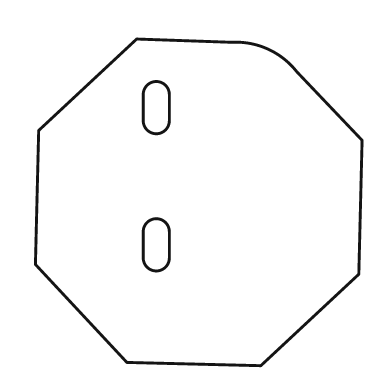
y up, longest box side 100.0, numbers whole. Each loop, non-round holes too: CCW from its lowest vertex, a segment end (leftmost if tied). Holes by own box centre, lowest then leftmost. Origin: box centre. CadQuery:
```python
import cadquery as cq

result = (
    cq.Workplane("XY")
    .moveTo(19.0, -50.0)
    .lineTo(49.0, -22.0)
    .lineTo(50.0, 19.0)
    .lineTo(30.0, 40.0)
    .threePointArc((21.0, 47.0), (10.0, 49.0))
    .lineTo(-19.0, 50.0)
    .lineTo(-49.0, 22.0)
    .lineTo(-50.0, -19.0)
    .lineTo(-22.0, -49.0)
    .close()
    .moveTo(-17.0, -17.0)
    .threePointArc((-13.0, -21.0), (-9.0, -17.0))
    .lineTo(-9.0, -9.0)
    .threePointArc((-13.0, -5.0), (-17.0, -9.0))
    .close()
    .moveTo(-17.0, 25.0)
    .threePointArc((-13.0, 21.0), (-9.0, 25.0))
    .lineTo(-9.0, 33.0)
    .threePointArc((-13.0, 37.0), (-17.0, 33.0))
    .close()
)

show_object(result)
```